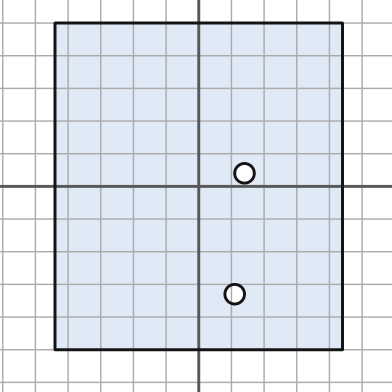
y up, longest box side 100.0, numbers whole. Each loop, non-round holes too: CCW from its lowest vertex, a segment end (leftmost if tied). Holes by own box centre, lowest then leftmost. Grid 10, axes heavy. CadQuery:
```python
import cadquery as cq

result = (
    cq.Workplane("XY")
    .moveTo(-44.0, -50.0)
    .lineTo(44.0, -50.0)
    .lineTo(44.0, 50.0)
    .lineTo(-44.0, 50.0)
    .close()
    .moveTo(11.0, -33.0)
    .circle(3.0)
    .moveTo(14.0, 4.0)
    .circle(3.0)
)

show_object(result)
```